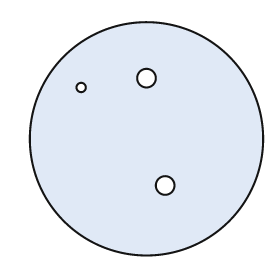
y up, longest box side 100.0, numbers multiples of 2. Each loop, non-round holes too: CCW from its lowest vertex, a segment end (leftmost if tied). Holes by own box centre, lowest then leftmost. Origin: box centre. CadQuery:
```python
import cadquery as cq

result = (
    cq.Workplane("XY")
    .moveTo(0.0, 0.0)
    .circle(50.0)
    .moveTo(8.0, -20.0)
    .circle(4.0)
    .moveTo(-28.0, 22.0)
    .circle(2.0)
    .moveTo(0.0, 26.0)
    .circle(4.0)
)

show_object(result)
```